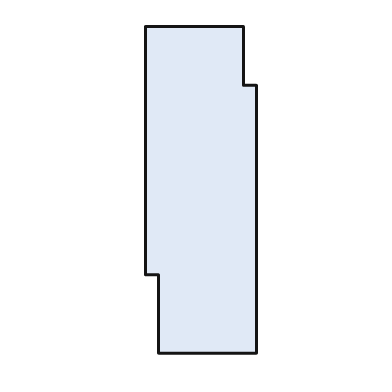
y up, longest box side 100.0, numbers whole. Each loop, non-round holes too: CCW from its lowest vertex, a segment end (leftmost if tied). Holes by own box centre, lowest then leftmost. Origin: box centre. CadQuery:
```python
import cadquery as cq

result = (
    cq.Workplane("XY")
    .moveTo(-13.0, -50.0)
    .lineTo(17.0, -50.0)
    .lineTo(17.0, 32.0)
    .lineTo(13.0, 32.0)
    .lineTo(13.0, 50.0)
    .lineTo(-17.0, 50.0)
    .lineTo(-17.0, -26.0)
    .lineTo(-13.0, -26.0)
    .close()
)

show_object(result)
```